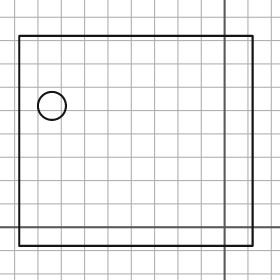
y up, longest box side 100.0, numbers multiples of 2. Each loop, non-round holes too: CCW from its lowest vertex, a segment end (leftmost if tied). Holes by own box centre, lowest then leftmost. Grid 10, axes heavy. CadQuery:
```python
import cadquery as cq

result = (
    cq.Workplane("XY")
    .moveTo(-88.0, -8.0)
    .lineTo(12.0, -8.0)
    .lineTo(12.0, 82.0)
    .lineTo(-88.0, 82.0)
    .close()
    .moveTo(-74.0, 52.0)
    .circle(6.0)
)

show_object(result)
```